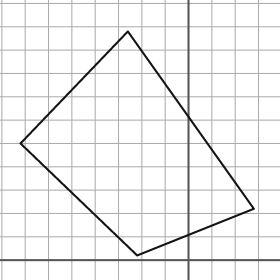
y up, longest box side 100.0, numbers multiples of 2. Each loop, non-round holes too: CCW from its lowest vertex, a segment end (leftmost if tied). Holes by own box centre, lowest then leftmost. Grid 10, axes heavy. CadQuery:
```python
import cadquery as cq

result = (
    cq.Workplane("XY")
    .moveTo(-22.0, 2.0)
    .lineTo(28.0, 22.0)
    .lineTo(-26.0, 98.0)
    .lineTo(-72.0, 50.0)
    .close()
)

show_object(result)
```